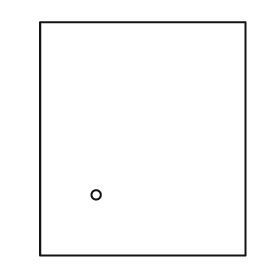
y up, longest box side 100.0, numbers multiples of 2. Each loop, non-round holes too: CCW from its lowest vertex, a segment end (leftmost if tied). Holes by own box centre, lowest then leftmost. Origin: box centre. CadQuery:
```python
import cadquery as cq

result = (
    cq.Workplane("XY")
    .moveTo(-44.0, -50.0)
    .lineTo(44.0, -50.0)
    .lineTo(44.0, 50.0)
    .lineTo(-44.0, 50.0)
    .close()
    .moveTo(-20.0, -24.0)
    .circle(2.0)
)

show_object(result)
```